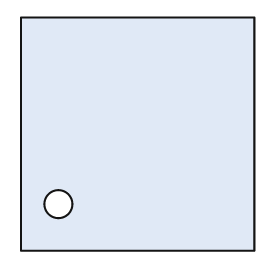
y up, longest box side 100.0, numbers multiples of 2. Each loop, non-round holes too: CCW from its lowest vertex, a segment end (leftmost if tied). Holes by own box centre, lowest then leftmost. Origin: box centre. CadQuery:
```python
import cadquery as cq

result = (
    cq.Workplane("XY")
    .moveTo(-50.0, -50.0)
    .lineTo(50.0, -50.0)
    .lineTo(50.0, 50.0)
    .lineTo(-50.0, 50.0)
    .close()
    .moveTo(-34.0, -30.0)
    .circle(6.0)
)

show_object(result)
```